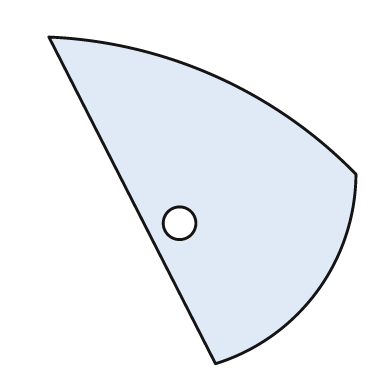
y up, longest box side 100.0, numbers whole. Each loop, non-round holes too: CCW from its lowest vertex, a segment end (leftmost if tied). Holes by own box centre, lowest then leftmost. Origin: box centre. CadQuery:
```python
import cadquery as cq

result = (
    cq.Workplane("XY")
    .moveTo(4.0, -50.0)
    .threePointArc((35.0, -28.0), (47.0, 8.0))
    .threePointArc((4.0, 38.0), (-47.0, 50.0))
    .close()
    .moveTo(-7.0, -7.0)
    .circle(5.0)
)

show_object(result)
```